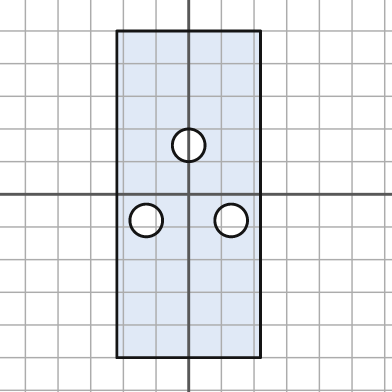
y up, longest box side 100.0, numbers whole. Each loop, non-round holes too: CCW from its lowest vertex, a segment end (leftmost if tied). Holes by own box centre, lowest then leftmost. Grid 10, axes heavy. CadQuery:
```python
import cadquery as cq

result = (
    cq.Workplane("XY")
    .moveTo(-22.0, -50.0)
    .lineTo(22.0, -50.0)
    .lineTo(22.0, 50.0)
    .lineTo(-22.0, 50.0)
    .close()
    .moveTo(-13.0, -8.0)
    .circle(5.0)
    .moveTo(13.0, -8.0)
    .circle(5.0)
    .moveTo(0.0, 15.0)
    .circle(5.0)
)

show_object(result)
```